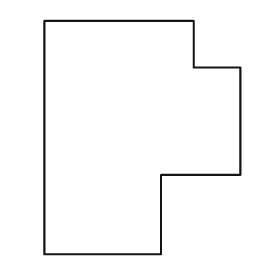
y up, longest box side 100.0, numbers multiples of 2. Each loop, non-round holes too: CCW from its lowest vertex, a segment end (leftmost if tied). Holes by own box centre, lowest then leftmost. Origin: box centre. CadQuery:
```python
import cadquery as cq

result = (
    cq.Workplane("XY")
    .moveTo(-42.0, -50.0)
    .lineTo(8.0, -50.0)
    .lineTo(8.0, -16.0)
    .lineTo(42.0, -16.0)
    .lineTo(42.0, 30.0)
    .lineTo(22.0, 30.0)
    .lineTo(22.0, 50.0)
    .lineTo(-42.0, 50.0)
    .close()
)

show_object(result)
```